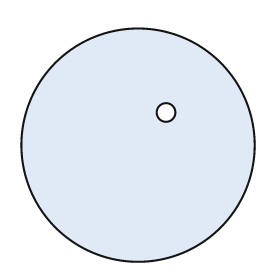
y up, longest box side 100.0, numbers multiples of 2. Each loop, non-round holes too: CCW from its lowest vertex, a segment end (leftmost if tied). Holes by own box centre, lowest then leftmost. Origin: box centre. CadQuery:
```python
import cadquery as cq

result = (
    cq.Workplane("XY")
    .moveTo(0.0, 0.0)
    .circle(50.0)
    .moveTo(12.0, 14.0)
    .circle(4.0)
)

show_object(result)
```